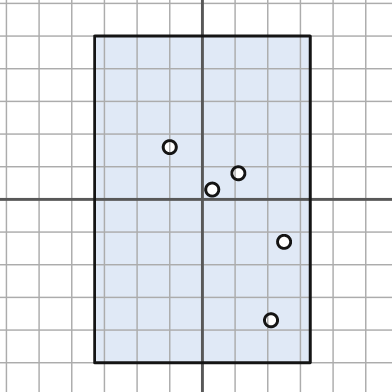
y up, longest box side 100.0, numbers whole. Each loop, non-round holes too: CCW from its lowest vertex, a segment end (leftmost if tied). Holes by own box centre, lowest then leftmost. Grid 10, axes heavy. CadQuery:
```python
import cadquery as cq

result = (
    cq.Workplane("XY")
    .moveTo(-33.0, -50.0)
    .lineTo(33.0, -50.0)
    .lineTo(33.0, 50.0)
    .lineTo(-33.0, 50.0)
    .close()
    .moveTo(21.0, -37.0)
    .circle(2.0)
    .moveTo(25.0, -13.0)
    .circle(2.0)
    .moveTo(3.0, 3.0)
    .circle(2.0)
    .moveTo(11.0, 8.0)
    .circle(2.0)
    .moveTo(-10.0, 16.0)
    .circle(2.0)
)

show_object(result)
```